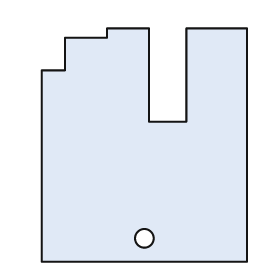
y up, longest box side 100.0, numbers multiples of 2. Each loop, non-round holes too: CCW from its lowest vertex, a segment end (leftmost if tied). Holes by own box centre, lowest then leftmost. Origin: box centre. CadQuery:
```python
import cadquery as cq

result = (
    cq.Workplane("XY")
    .moveTo(-44.0, -50.0)
    .lineTo(44.0, -50.0)
    .lineTo(44.0, 50.0)
    .lineTo(18.0, 50.0)
    .lineTo(18.0, 10.0)
    .lineTo(2.0, 10.0)
    .lineTo(2.0, 50.0)
    .lineTo(-16.0, 50.0)
    .lineTo(-16.0, 46.0)
    .lineTo(-34.0, 46.0)
    .lineTo(-34.0, 32.0)
    .lineTo(-44.0, 32.0)
    .close()
    .moveTo(0.0, -40.0)
    .circle(4.0)
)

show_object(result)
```